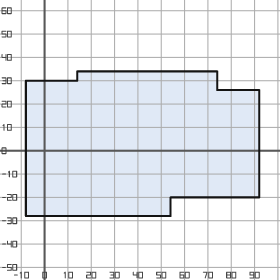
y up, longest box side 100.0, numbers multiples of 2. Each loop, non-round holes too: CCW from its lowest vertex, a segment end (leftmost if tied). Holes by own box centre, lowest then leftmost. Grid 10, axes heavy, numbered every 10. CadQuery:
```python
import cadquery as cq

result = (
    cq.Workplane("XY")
    .moveTo(-8.0, -28.0)
    .lineTo(54.0, -28.0)
    .lineTo(54.0, -20.0)
    .lineTo(92.0, -20.0)
    .lineTo(92.0, 26.0)
    .lineTo(74.0, 26.0)
    .lineTo(74.0, 34.0)
    .lineTo(14.0, 34.0)
    .lineTo(14.0, 30.0)
    .lineTo(-8.0, 30.0)
    .close()
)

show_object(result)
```